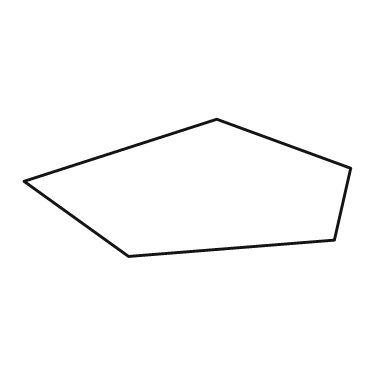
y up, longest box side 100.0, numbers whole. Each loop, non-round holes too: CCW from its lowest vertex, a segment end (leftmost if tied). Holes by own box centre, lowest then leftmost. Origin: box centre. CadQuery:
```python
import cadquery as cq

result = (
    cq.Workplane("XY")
    .moveTo(-18.0, -21.0)
    .lineTo(45.0, -16.0)
    .lineTo(50.0, 6.0)
    .lineTo(9.0, 21.0)
    .lineTo(-50.0, 2.0)
    .close()
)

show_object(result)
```